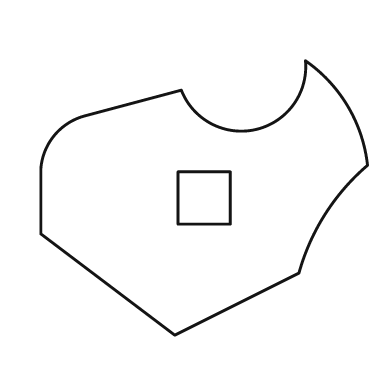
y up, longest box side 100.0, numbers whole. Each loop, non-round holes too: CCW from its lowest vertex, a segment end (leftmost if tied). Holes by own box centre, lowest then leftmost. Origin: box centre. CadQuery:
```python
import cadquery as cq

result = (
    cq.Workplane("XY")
    .moveTo(-9.0, -42.0)
    .lineTo(29.0, -23.0)
    .threePointArc((37.0, -5.0), (50.0, 10.0))
    .threePointArc((44.0, 28.0), (31.0, 42.0))
    .threePointArc((16.0, 21.0), (-7.0, 33.0))
    .lineTo(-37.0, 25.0)
    .threePointArc((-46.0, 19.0), (-50.0, 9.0))
    .lineTo(-50.0, -11.0)
    .close()
    .moveTo(-8.0, -8.0)
    .lineTo(8.0, -8.0)
    .lineTo(8.0, 8.0)
    .lineTo(-8.0, 8.0)
    .close()
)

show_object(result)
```